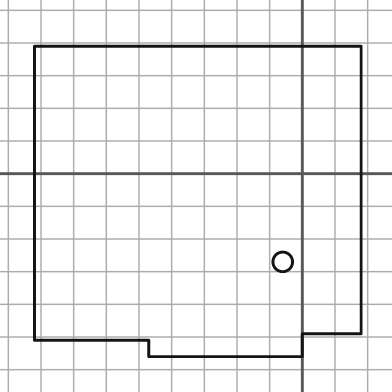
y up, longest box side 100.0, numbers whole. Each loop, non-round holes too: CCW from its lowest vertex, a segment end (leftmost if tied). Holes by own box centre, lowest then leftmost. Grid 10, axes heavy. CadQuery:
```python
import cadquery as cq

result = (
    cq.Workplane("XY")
    .moveTo(-47.0, -56.0)
    .lineTo(0.0, -56.0)
    .lineTo(0.0, -49.0)
    .lineTo(18.0, -49.0)
    .lineTo(18.0, 39.0)
    .lineTo(-82.0, 39.0)
    .lineTo(-82.0, -51.0)
    .lineTo(-47.0, -51.0)
    .close()
    .moveTo(-6.0, -27.0)
    .circle(3.0)
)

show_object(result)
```